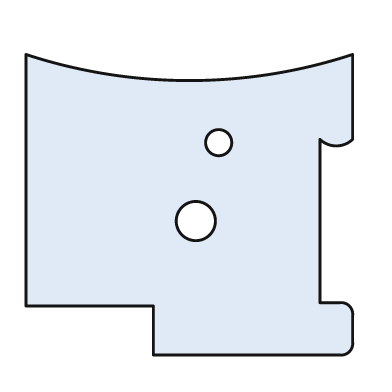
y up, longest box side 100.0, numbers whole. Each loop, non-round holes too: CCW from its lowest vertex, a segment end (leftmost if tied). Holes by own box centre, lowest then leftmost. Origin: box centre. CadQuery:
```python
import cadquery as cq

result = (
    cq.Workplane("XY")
    .moveTo(-11.0, -46.0)
    .lineTo(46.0, -46.0)
    .threePointArc((49.0, -45.0), (50.0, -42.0))
    .lineTo(50.0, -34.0)
    .threePointArc((49.0, -31.0), (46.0, -30.0))
    .lineTo(40.0, -30.0)
    .lineTo(40.0, 20.0)
    .threePointArc((45.0, 18.0), (50.0, 20.0))
    .lineTo(50.0, 46.0)
    .threePointArc((0.0, 38.0), (-50.0, 46.0))
    .lineTo(-50.0, -31.0)
    .lineTo(-11.0, -31.0)
    .close()
    .moveTo(2.0, -5.0)
    .circle(6.0)
    .moveTo(9.0, 19.0)
    .circle(4.0)
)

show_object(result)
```